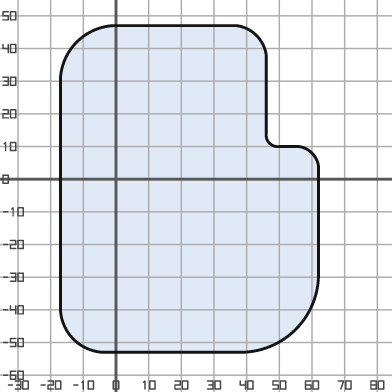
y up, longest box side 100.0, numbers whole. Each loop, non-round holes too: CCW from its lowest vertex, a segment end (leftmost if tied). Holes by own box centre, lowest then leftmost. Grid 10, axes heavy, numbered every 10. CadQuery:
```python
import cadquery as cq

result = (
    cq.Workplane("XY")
    .moveTo(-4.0, -53.0)
    .lineTo(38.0, -53.0)
    .threePointArc((55.0, -46.0), (62.0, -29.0))
    .lineTo(62.0, 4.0)
    .threePointArc((60.0, 8.0), (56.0, 10.0))
    .lineTo(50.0, 10.0)
    .threePointArc((47.0, 11.0), (46.0, 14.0))
    .lineTo(46.0, 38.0)
    .threePointArc((43.0, 44.0), (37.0, 47.0))
    .lineTo(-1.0, 47.0)
    .threePointArc((-12.0, 42.0), (-17.0, 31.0))
    .lineTo(-17.0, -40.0)
    .threePointArc((-13.0, -49.0), (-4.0, -53.0))
    .close()
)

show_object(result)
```